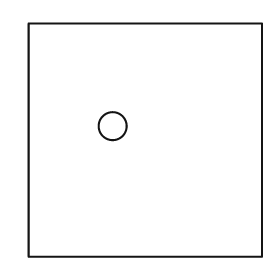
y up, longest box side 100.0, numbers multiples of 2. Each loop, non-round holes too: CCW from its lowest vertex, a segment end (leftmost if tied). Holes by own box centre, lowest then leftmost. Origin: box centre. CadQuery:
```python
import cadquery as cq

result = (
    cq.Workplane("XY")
    .moveTo(-50.0, -50.0)
    .lineTo(50.0, -50.0)
    .lineTo(50.0, 50.0)
    .lineTo(-50.0, 50.0)
    .close()
    .moveTo(-14.0, 6.0)
    .circle(6.0)
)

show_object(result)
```